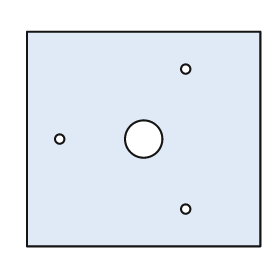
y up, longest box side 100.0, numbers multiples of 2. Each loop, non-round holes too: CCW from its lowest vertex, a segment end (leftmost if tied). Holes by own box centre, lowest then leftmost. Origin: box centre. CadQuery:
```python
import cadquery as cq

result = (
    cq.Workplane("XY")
    .moveTo(-50.0, -46.0)
    .lineTo(50.0, -46.0)
    .lineTo(50.0, 46.0)
    .lineTo(-50.0, 46.0)
    .close()
    .moveTo(18.0, -30.0)
    .circle(2.0)
    .moveTo(-36.0, 0.0)
    .circle(2.0)
    .moveTo(0.0, 0.0)
    .circle(8.0)
    .moveTo(18.0, 30.0)
    .circle(2.0)
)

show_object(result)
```